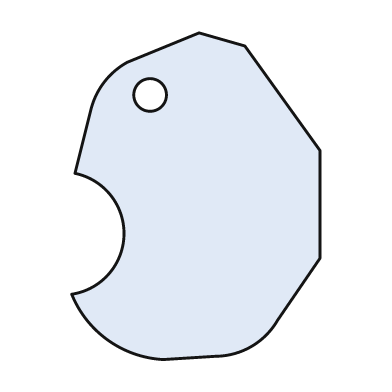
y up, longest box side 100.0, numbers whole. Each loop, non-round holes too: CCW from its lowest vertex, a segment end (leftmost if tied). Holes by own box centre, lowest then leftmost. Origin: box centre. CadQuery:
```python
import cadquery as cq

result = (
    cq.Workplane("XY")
    .moveTo(-10.0, -50.0)
    .lineTo(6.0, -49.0)
    .threePointArc((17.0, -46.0), (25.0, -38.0))
    .lineTo(38.0, -19.0)
    .lineTo(38.0, 14.0)
    .lineTo(15.0, 46.0)
    .lineTo(1.0, 50.0)
    .lineTo(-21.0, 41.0)
    .threePointArc((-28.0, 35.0), (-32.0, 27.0))
    .lineTo(-37.0, 7.0)
    .threePointArc((-22.0, -12.0), (-38.0, -30.0))
    .threePointArc((-27.0, -44.0), (-10.0, -50.0))
    .close()
    .moveTo(-14.0, 31.0)
    .circle(5.0)
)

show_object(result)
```